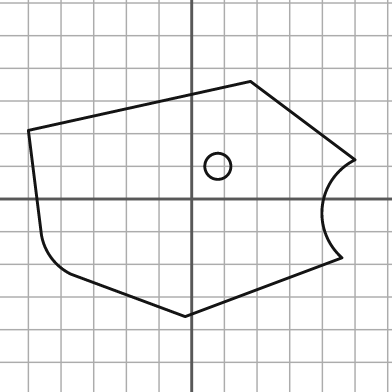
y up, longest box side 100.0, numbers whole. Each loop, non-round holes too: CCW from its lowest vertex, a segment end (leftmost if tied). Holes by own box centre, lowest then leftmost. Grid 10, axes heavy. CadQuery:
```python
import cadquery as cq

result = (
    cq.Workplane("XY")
    .moveTo(-2.0, -36.0)
    .lineTo(46.0, -18.0)
    .threePointArc((40.0, -2.0), (50.0, 12.0))
    .lineTo(18.0, 36.0)
    .lineTo(-50.0, 21.0)
    .lineTo(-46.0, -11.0)
    .threePointArc((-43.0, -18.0), (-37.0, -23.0))
    .close()
    .moveTo(8.0, 10.0)
    .circle(4.0)
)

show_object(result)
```